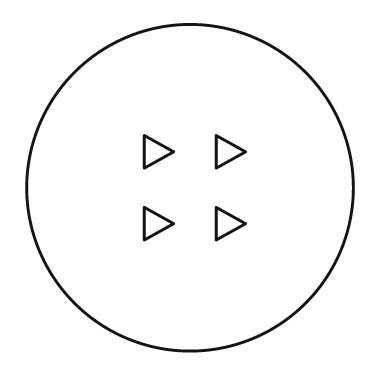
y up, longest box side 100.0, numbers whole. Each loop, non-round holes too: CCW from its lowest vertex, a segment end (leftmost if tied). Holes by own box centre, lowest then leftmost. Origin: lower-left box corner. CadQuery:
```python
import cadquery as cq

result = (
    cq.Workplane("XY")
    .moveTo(50.0, 50.0)
    .circle(50.0)
    .moveTo(36.0, 34.0)
    .lineTo(45.0, 39.0)
    .lineTo(36.0, 44.0)
    .close()
    .moveTo(58.0, 34.0)
    .lineTo(67.0, 39.0)
    .lineTo(58.0, 44.0)
    .close()
    .moveTo(36.0, 56.0)
    .lineTo(45.0, 61.0)
    .lineTo(36.0, 66.0)
    .close()
    .moveTo(58.0, 56.0)
    .lineTo(67.0, 61.0)
    .lineTo(58.0, 66.0)
    .close()
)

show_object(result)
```